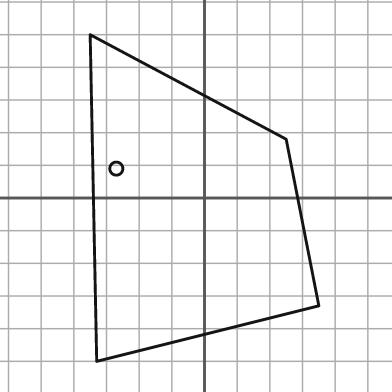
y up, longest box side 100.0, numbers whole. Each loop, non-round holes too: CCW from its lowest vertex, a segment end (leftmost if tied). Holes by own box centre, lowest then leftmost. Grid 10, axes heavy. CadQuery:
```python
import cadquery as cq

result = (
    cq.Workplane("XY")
    .moveTo(-33.0, -50.0)
    .lineTo(35.0, -33.0)
    .lineTo(25.0, 18.0)
    .lineTo(-35.0, 50.0)
    .close()
    .moveTo(-27.0, 9.0)
    .circle(2.0)
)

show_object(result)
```